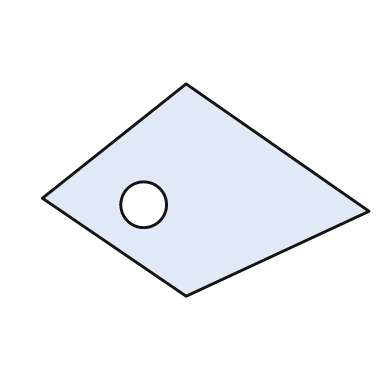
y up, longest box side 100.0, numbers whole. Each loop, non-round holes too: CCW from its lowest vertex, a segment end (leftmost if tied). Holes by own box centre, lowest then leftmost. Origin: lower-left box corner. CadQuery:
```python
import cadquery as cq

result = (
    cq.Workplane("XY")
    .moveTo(44.0, 0.0)
    .lineTo(100.0, 26.0)
    .lineTo(44.0, 65.0)
    .lineTo(0.0, 30.0)
    .close()
    .moveTo(31.0, 28.0)
    .circle(7.0)
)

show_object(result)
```